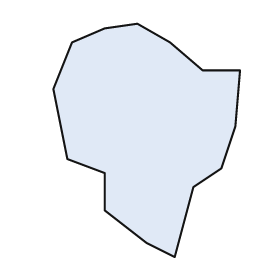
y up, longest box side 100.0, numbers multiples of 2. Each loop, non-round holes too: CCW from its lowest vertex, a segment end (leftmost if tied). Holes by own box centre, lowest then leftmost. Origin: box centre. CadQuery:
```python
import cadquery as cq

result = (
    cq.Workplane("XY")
    .moveTo(12.0, -50.0)
    .lineTo(20.0, -20.0)
    .lineTo(32.0, -12.0)
    .lineTo(38.0, 6.0)
    .lineTo(40.0, 30.0)
    .lineTo(24.0, 30.0)
    .lineTo(10.0, 42.0)
    .lineTo(-4.0, 50.0)
    .lineTo(-18.0, 48.0)
    .lineTo(-32.0, 42.0)
    .lineTo(-40.0, 22.0)
    .lineTo(-34.0, -8.0)
    .lineTo(-18.0, -14.0)
    .lineTo(-18.0, -30.0)
    .lineTo(0.0, -44.0)
    .close()
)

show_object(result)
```